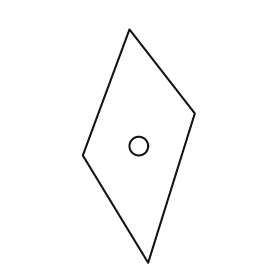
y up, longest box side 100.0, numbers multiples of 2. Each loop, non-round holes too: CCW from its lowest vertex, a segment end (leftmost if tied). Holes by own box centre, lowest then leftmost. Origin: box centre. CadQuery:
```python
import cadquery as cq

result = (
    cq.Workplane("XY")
    .moveTo(4.0, -50.0)
    .lineTo(24.0, 14.0)
    .lineTo(-4.0, 50.0)
    .lineTo(-24.0, -4.0)
    .close()
    .moveTo(0.0, 0.0)
    .circle(4.0)
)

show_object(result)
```